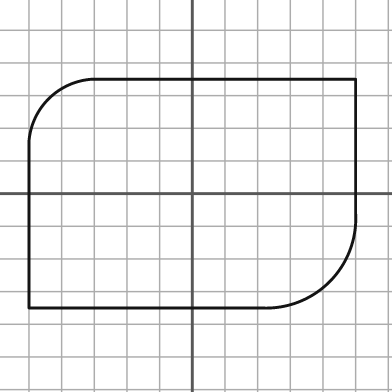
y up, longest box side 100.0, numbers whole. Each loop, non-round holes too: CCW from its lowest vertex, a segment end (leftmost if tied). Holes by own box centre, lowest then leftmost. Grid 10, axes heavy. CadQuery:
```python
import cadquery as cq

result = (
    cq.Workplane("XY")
    .moveTo(-50.0, -35.0)
    .lineTo(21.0, -35.0)
    .threePointArc((42.0, -27.0), (50.0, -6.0))
    .lineTo(50.0, 35.0)
    .lineTo(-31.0, 35.0)
    .threePointArc((-44.0, 29.0), (-50.0, 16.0))
    .close()
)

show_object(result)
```